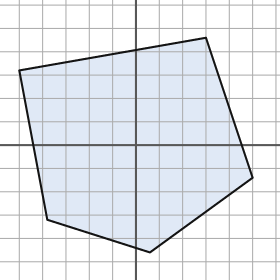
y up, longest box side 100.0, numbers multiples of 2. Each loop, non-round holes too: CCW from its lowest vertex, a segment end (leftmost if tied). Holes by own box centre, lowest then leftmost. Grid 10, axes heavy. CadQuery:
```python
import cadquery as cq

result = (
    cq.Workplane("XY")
    .moveTo(6.0, -46.0)
    .lineTo(50.0, -14.0)
    .lineTo(30.0, 46.0)
    .lineTo(-50.0, 32.0)
    .lineTo(-38.0, -32.0)
    .close()
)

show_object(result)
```